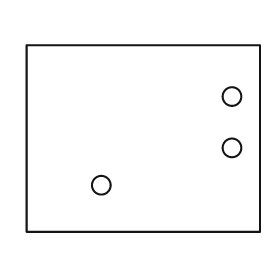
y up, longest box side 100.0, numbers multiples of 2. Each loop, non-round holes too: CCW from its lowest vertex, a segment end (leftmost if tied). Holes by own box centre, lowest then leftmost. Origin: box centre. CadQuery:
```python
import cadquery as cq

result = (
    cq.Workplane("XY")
    .moveTo(-50.0, -40.0)
    .lineTo(50.0, -40.0)
    .lineTo(50.0, 40.0)
    .lineTo(-50.0, 40.0)
    .close()
    .moveTo(-18.0, -20.0)
    .circle(4.0)
    .moveTo(38.0, -4.0)
    .circle(4.0)
    .moveTo(38.0, 18.0)
    .circle(4.0)
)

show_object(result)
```